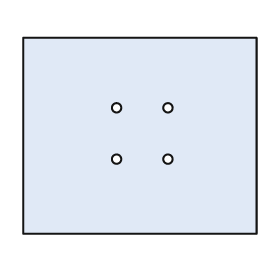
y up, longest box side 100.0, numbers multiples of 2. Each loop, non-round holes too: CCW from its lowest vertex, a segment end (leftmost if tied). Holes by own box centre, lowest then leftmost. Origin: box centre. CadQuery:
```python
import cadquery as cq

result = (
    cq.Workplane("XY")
    .moveTo(-50.0, -42.0)
    .lineTo(50.0, -42.0)
    .lineTo(50.0, 42.0)
    .lineTo(-50.0, 42.0)
    .close()
    .moveTo(-10.0, -10.0)
    .circle(2.0)
    .moveTo(12.0, -10.0)
    .circle(2.0)
    .moveTo(-10.0, 12.0)
    .circle(2.0)
    .moveTo(12.0, 12.0)
    .circle(2.0)
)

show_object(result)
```